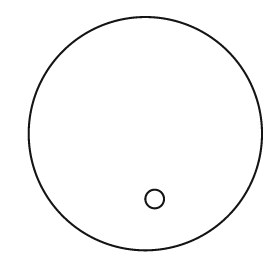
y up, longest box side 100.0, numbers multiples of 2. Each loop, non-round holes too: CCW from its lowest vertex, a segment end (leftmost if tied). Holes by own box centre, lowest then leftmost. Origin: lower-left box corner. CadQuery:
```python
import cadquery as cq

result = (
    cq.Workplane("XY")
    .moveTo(50.0, 50.0)
    .circle(50.0)
    .moveTo(54.0, 22.0)
    .circle(4.0)
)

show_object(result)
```